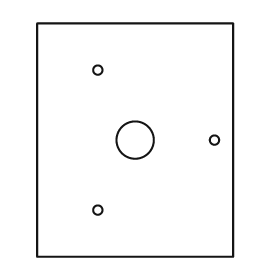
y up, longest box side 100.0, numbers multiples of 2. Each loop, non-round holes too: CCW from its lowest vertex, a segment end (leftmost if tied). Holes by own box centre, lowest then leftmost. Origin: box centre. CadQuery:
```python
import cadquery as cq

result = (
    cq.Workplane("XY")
    .moveTo(-42.0, -50.0)
    .lineTo(42.0, -50.0)
    .lineTo(42.0, 50.0)
    .lineTo(-42.0, 50.0)
    .close()
    .moveTo(-16.0, -30.0)
    .circle(2.0)
    .moveTo(0.0, 0.0)
    .circle(8.0)
    .moveTo(34.0, 0.0)
    .circle(2.0)
    .moveTo(-16.0, 30.0)
    .circle(2.0)
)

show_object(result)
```